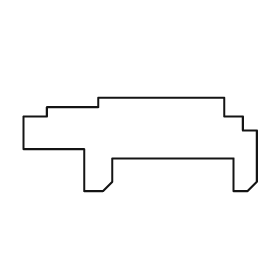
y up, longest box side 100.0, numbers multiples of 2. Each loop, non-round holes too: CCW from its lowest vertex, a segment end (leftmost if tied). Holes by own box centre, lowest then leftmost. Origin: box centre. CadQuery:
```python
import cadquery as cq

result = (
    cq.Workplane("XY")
    .moveTo(-24.0, -20.0)
    .lineTo(-16.0, -20.0)
    .lineTo(-12.0, -16.0)
    .lineTo(-12.0, -6.0)
    .lineTo(40.0, -6.0)
    .lineTo(40.0, -20.0)
    .lineTo(46.0, -20.0)
    .lineTo(50.0, -16.0)
    .lineTo(50.0, 6.0)
    .lineTo(44.0, 6.0)
    .lineTo(44.0, 12.0)
    .lineTo(36.0, 12.0)
    .lineTo(36.0, 20.0)
    .lineTo(-18.0, 20.0)
    .lineTo(-18.0, 16.0)
    .lineTo(-40.0, 16.0)
    .lineTo(-40.0, 12.0)
    .lineTo(-50.0, 12.0)
    .lineTo(-50.0, -2.0)
    .lineTo(-24.0, -2.0)
    .close()
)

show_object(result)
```